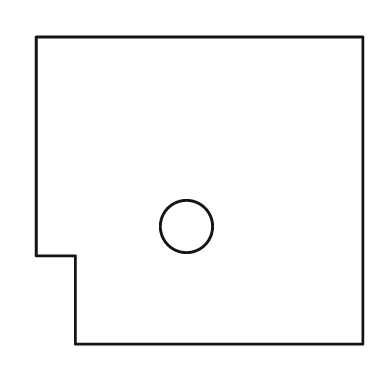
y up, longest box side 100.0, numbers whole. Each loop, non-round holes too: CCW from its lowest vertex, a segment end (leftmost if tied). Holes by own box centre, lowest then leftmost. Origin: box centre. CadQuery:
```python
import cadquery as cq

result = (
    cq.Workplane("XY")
    .moveTo(-38.0, -47.0)
    .lineTo(50.0, -47.0)
    .lineTo(50.0, 47.0)
    .lineTo(-50.0, 47.0)
    .lineTo(-50.0, -20.0)
    .lineTo(-38.0, -20.0)
    .close()
    .moveTo(-4.0, -11.0)
    .circle(8.0)
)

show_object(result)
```